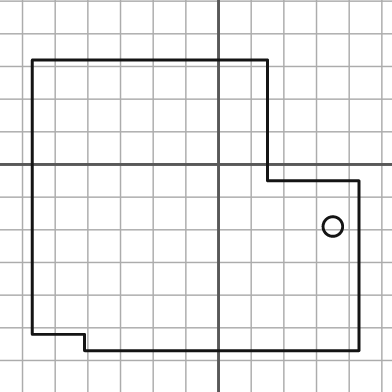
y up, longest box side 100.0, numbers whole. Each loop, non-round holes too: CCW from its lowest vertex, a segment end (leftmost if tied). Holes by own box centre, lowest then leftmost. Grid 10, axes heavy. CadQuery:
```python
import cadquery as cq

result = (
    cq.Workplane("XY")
    .moveTo(-41.0, -57.0)
    .lineTo(43.0, -57.0)
    .lineTo(43.0, -5.0)
    .lineTo(15.0, -5.0)
    .lineTo(15.0, 32.0)
    .lineTo(-57.0, 32.0)
    .lineTo(-57.0, -52.0)
    .lineTo(-41.0, -52.0)
    .close()
    .moveTo(35.0, -19.0)
    .circle(3.0)
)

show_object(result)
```